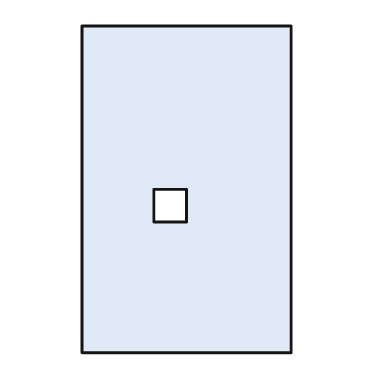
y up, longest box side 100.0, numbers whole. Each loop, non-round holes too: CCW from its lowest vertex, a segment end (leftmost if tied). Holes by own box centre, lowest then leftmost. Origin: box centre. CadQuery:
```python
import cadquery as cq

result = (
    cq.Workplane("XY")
    .moveTo(-32.0, -50.0)
    .lineTo(32.0, -50.0)
    .lineTo(32.0, 50.0)
    .lineTo(-32.0, 50.0)
    .close()
    .moveTo(-10.0, -10.0)
    .lineTo(0.0, -10.0)
    .lineTo(0.0, 0.0)
    .lineTo(-10.0, 0.0)
    .close()
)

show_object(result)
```